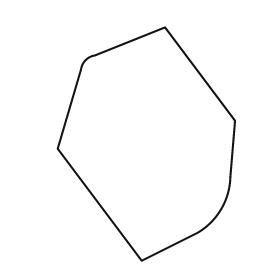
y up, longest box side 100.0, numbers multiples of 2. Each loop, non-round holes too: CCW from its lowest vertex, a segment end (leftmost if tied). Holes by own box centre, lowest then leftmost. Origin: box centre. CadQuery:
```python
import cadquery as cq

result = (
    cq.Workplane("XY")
    .moveTo(-2.0, -50.0)
    .lineTo(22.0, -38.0)
    .threePointArc((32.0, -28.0), (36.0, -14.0))
    .lineTo(38.0, 10.0)
    .lineTo(8.0, 50.0)
    .lineTo(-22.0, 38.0)
    .threePointArc((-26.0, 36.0), (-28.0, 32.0))
    .lineTo(-38.0, -2.0)
    .close()
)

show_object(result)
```